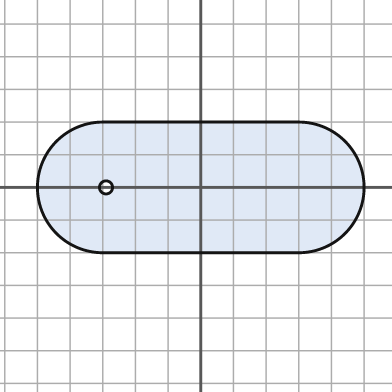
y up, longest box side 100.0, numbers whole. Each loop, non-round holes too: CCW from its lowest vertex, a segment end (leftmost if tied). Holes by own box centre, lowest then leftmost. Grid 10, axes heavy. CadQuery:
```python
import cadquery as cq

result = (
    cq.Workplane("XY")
    .moveTo(-30.0, -20.0)
    .lineTo(30.0, -20.0)
    .threePointArc((50.0, 0.0), (30.0, 20.0))
    .lineTo(-30.0, 20.0)
    .threePointArc((-50.0, 0.0), (-30.0, -20.0))
    .close()
    .moveTo(-29.0, 0.0)
    .circle(2.0)
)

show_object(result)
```